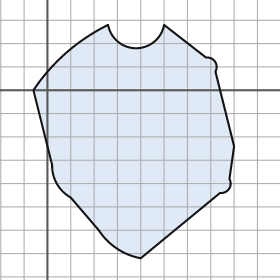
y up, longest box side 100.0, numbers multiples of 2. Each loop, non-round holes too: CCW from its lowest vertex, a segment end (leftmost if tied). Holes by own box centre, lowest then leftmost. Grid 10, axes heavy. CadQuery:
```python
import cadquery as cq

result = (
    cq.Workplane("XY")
    .moveTo(40.0, -72.0)
    .lineTo(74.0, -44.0)
    .threePointArc((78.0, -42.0), (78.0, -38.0))
    .lineTo(80.0, -24.0)
    .lineTo(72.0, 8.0)
    .threePointArc((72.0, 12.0), (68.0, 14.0))
    .lineTo(50.0, 28.0)
    .threePointArc((38.0, 18.0), (26.0, 28.0))
    .threePointArc((8.0, 16.0), (-6.0, 0.0))
    .lineTo(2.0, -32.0)
    .threePointArc((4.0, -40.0), (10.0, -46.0))
    .lineTo(22.0, -60.0)
    .threePointArc((30.0, -68.0), (40.0, -72.0))
    .close()
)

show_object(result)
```